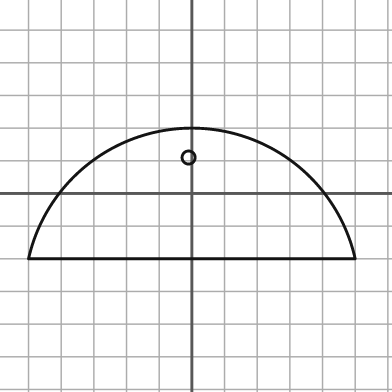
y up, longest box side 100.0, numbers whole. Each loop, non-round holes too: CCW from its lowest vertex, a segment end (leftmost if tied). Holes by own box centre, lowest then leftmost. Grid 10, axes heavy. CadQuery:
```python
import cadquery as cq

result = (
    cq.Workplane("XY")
    .moveTo(-50.0, -20.0)
    .lineTo(50.0, -20.0)
    .threePointArc((0.0, 20.0), (-50.0, -20.0))
    .close()
    .moveTo(-1.0, 11.0)
    .circle(2.0)
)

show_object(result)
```